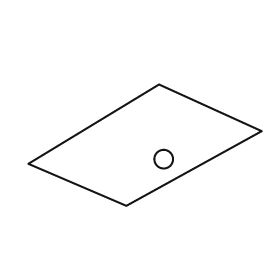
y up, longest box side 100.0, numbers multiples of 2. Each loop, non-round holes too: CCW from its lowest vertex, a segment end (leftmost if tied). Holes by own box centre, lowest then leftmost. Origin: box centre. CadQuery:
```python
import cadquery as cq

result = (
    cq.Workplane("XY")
    .moveTo(-8.0, -26.0)
    .lineTo(50.0, 6.0)
    .lineTo(6.0, 26.0)
    .lineTo(-50.0, -8.0)
    .close()
    .moveTo(8.0, -6.0)
    .circle(4.0)
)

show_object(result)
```